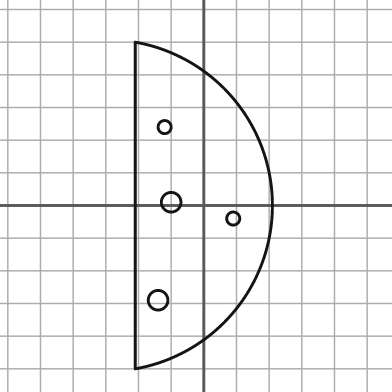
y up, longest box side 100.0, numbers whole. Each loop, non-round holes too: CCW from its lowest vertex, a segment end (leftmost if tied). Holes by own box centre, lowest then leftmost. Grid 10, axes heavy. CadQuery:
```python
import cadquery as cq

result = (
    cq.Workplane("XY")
    .moveTo(-21.0, -50.0)
    .threePointArc((21.0, 0.0), (-21.0, 50.0))
    .close()
    .moveTo(-14.0, -29.0)
    .circle(3.0)
    .moveTo(9.0, -4.0)
    .circle(2.0)
    .moveTo(-10.0, 1.0)
    .circle(3.0)
    .moveTo(-12.0, 24.0)
    .circle(2.0)
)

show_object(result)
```